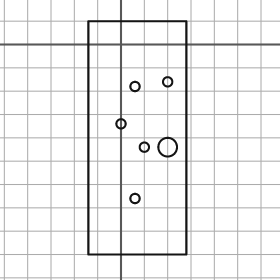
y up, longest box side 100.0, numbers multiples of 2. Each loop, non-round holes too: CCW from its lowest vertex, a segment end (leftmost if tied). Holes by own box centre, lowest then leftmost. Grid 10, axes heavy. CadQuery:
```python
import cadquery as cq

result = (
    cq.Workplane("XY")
    .moveTo(-14.0, -90.0)
    .lineTo(28.0, -90.0)
    .lineTo(28.0, 10.0)
    .lineTo(-14.0, 10.0)
    .close()
    .moveTo(6.0, -66.0)
    .circle(2.0)
    .moveTo(10.0, -44.0)
    .circle(2.0)
    .moveTo(20.0, -44.0)
    .circle(4.0)
    .moveTo(0.0, -34.0)
    .circle(2.0)
    .moveTo(6.0, -18.0)
    .circle(2.0)
    .moveTo(20.0, -16.0)
    .circle(2.0)
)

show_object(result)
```